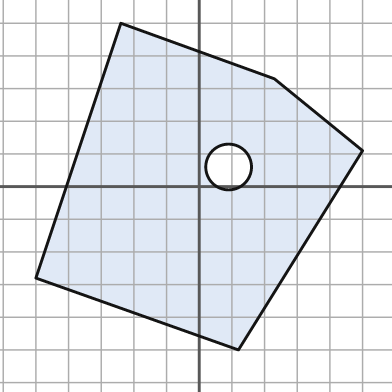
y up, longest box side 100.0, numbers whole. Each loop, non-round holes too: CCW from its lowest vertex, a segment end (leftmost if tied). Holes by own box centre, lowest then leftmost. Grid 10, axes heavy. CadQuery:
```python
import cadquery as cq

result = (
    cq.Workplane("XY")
    .moveTo(12.0, -50.0)
    .lineTo(50.0, 11.0)
    .lineTo(23.0, 33.0)
    .lineTo(-24.0, 50.0)
    .lineTo(-50.0, -28.0)
    .close()
    .moveTo(9.0, 6.0)
    .circle(7.0)
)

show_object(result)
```